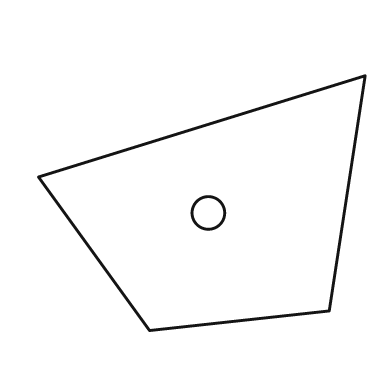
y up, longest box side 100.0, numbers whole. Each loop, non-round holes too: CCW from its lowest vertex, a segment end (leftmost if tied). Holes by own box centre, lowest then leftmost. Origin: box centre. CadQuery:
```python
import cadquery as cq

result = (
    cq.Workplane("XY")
    .moveTo(-16.0, -39.0)
    .lineTo(39.0, -33.0)
    .lineTo(50.0, 39.0)
    .lineTo(-50.0, 8.0)
    .close()
    .moveTo(2.0, -3.0)
    .circle(5.0)
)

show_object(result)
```